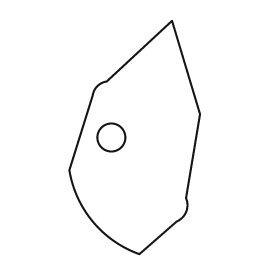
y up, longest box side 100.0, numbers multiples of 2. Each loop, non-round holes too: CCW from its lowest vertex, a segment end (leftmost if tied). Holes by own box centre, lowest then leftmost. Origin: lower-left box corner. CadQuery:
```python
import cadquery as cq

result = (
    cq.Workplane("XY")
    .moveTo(30.0, 0.0)
    .lineTo(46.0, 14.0)
    .threePointArc((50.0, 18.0), (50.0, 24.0))
    .lineTo(56.0, 60.0)
    .lineTo(44.0, 100.0)
    .lineTo(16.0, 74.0)
    .threePointArc((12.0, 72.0), (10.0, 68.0))
    .lineTo(0.0, 36.0)
    .threePointArc((10.0, 14.0), (30.0, 0.0))
    .close()
    .moveTo(18.0, 50.0)
    .circle(6.0)
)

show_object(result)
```